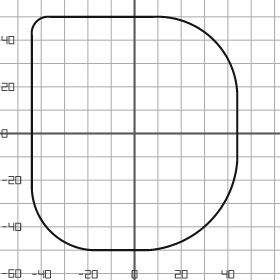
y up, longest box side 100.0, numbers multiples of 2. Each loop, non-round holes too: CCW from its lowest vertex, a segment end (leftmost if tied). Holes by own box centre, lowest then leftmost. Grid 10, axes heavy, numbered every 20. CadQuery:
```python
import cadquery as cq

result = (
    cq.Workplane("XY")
    .moveTo(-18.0, -50.0)
    .lineTo(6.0, -50.0)
    .threePointArc((32.0, -38.0), (44.0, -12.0))
    .lineTo(44.0, 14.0)
    .threePointArc((34.0, 40.0), (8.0, 50.0))
    .lineTo(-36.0, 50.0)
    .threePointArc((-42.0, 48.0), (-44.0, 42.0))
    .lineTo(-44.0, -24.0)
    .threePointArc((-36.0, -42.0), (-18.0, -50.0))
    .close()
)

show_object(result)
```